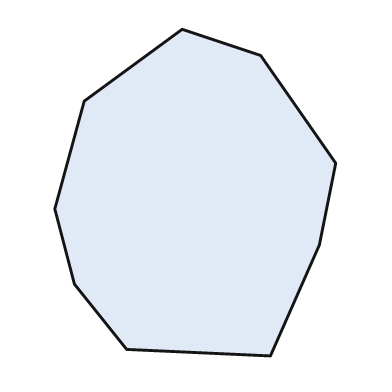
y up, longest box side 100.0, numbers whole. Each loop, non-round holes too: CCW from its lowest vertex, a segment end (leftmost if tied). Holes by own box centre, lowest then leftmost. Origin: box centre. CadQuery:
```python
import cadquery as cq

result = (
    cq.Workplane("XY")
    .moveTo(23.0, -50.0)
    .lineTo(38.0, -16.0)
    .lineTo(43.0, 9.0)
    .lineTo(20.0, 42.0)
    .lineTo(-4.0, 50.0)
    .lineTo(-34.0, 28.0)
    .lineTo(-43.0, -5.0)
    .lineTo(-37.0, -28.0)
    .lineTo(-21.0, -48.0)
    .close()
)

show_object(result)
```